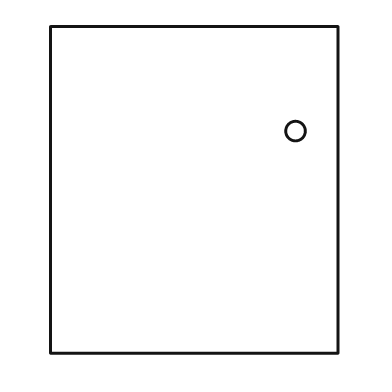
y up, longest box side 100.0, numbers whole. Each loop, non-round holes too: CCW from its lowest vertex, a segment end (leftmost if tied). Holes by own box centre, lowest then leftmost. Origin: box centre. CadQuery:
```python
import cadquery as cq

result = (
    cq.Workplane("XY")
    .moveTo(-44.0, -50.0)
    .lineTo(44.0, -50.0)
    .lineTo(44.0, 50.0)
    .lineTo(-44.0, 50.0)
    .close()
    .moveTo(31.0, 18.0)
    .circle(3.0)
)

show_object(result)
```